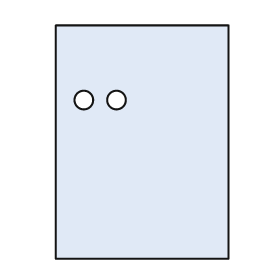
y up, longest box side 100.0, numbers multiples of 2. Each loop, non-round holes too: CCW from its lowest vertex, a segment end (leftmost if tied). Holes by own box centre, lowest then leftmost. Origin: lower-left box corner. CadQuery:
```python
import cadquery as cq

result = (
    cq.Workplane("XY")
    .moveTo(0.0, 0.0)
    .lineTo(74.0, 0.0)
    .lineTo(74.0, 100.0)
    .lineTo(0.0, 100.0)
    .close()
    .moveTo(12.0, 68.0)
    .circle(4.0)
    .moveTo(26.0, 68.0)
    .circle(4.0)
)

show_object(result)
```